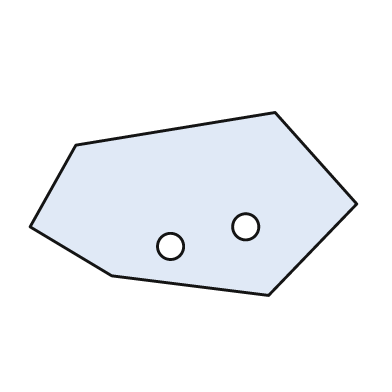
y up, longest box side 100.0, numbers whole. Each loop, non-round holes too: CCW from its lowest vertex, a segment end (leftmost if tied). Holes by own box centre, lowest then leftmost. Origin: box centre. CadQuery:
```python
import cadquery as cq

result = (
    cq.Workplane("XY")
    .moveTo(23.0, -28.0)
    .lineTo(50.0, 0.0)
    .lineTo(25.0, 28.0)
    .lineTo(-36.0, 18.0)
    .lineTo(-50.0, -7.0)
    .lineTo(-25.0, -22.0)
    .close()
    .moveTo(-7.0, -13.0)
    .circle(4.0)
    .moveTo(16.0, -7.0)
    .circle(4.0)
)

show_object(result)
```